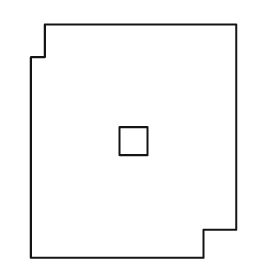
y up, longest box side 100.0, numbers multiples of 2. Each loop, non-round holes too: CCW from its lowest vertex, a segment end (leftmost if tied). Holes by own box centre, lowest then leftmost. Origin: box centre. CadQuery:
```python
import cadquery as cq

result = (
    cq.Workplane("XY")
    .moveTo(-44.0, -50.0)
    .lineTo(30.0, -50.0)
    .lineTo(30.0, -38.0)
    .lineTo(44.0, -38.0)
    .lineTo(44.0, 50.0)
    .lineTo(-38.0, 50.0)
    .lineTo(-38.0, 36.0)
    .lineTo(-44.0, 36.0)
    .close()
    .moveTo(-6.0, -6.0)
    .lineTo(6.0, -6.0)
    .lineTo(6.0, 6.0)
    .lineTo(-6.0, 6.0)
    .close()
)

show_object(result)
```